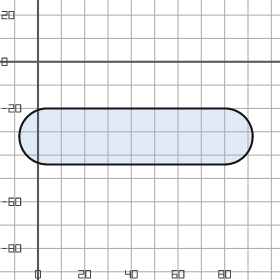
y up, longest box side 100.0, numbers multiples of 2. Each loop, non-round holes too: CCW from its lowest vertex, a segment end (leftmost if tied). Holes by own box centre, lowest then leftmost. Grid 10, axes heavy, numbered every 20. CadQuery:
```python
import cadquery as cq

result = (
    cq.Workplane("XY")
    .moveTo(4.0, -44.0)
    .lineTo(80.0, -44.0)
    .threePointArc((92.0, -32.0), (80.0, -20.0))
    .lineTo(4.0, -20.0)
    .threePointArc((-8.0, -32.0), (4.0, -44.0))
    .close()
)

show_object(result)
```